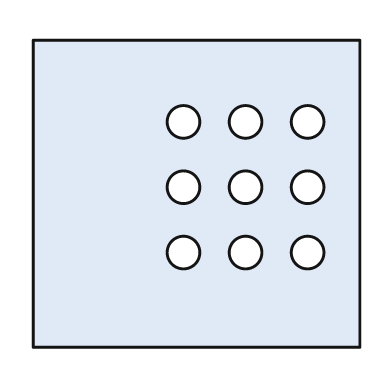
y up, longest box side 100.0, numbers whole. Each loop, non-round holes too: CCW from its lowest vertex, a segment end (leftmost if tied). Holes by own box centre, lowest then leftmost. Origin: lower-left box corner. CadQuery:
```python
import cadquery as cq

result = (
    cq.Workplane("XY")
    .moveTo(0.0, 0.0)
    .lineTo(100.0, 0.0)
    .lineTo(100.0, 94.0)
    .lineTo(0.0, 94.0)
    .close()
    .moveTo(46.0, 29.0)
    .circle(5.0)
    .moveTo(65.0, 29.0)
    .circle(5.0)
    .moveTo(84.0, 29.0)
    .circle(5.0)
    .moveTo(46.0, 49.0)
    .circle(5.0)
    .moveTo(65.0, 49.0)
    .circle(5.0)
    .moveTo(84.0, 49.0)
    .circle(5.0)
    .moveTo(46.0, 69.0)
    .circle(5.0)
    .moveTo(65.0, 69.0)
    .circle(5.0)
    .moveTo(84.0, 69.0)
    .circle(5.0)
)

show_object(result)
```